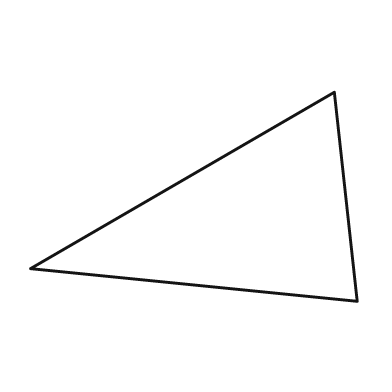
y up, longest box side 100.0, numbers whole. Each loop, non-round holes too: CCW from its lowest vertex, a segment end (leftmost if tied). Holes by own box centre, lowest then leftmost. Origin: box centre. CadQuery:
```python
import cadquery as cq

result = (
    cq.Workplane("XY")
    .moveTo(50.0, -32.0)
    .lineTo(43.0, 32.0)
    .lineTo(-50.0, -22.0)
    .close()
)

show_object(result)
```